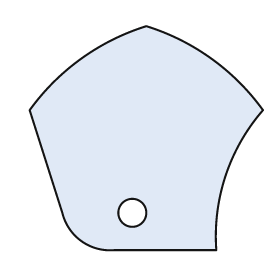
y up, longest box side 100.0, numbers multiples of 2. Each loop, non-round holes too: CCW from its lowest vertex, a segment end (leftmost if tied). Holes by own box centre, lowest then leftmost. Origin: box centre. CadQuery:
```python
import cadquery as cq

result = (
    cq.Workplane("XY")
    .moveTo(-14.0, -48.0)
    .lineTo(30.0, -48.0)
    .threePointArc((34.0, -16.0), (50.0, 12.0))
    .threePointArc((28.0, 34.0), (0.0, 48.0))
    .threePointArc((-28.0, 34.0), (-50.0, 12.0))
    .lineTo(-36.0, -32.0)
    .threePointArc((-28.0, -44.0), (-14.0, -48.0))
    .close()
    .moveTo(-6.0, -32.0)
    .circle(6.0)
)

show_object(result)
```